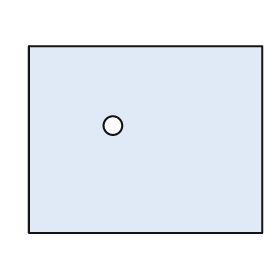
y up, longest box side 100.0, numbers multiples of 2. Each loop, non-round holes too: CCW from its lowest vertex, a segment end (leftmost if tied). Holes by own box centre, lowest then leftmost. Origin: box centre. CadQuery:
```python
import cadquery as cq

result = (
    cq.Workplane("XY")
    .moveTo(-50.0, -40.0)
    .lineTo(50.0, -40.0)
    .lineTo(50.0, 40.0)
    .lineTo(-50.0, 40.0)
    .close()
    .moveTo(-14.0, 6.0)
    .circle(4.0)
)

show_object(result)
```